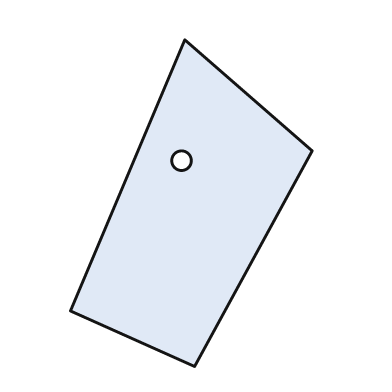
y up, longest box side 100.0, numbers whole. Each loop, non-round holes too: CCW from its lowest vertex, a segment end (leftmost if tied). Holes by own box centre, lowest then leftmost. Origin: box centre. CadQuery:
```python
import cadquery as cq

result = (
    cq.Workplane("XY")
    .moveTo(1.0, -50.0)
    .lineTo(37.0, 16.0)
    .lineTo(-2.0, 50.0)
    .lineTo(-37.0, -33.0)
    .close()
    .moveTo(-3.0, 13.0)
    .circle(3.0)
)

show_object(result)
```